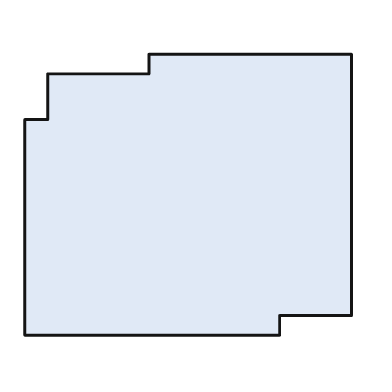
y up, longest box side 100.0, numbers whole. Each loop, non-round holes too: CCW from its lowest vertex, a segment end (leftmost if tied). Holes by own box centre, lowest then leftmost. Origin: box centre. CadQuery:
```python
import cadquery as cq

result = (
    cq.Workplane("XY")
    .moveTo(-50.0, -43.0)
    .lineTo(28.0, -43.0)
    .lineTo(28.0, -37.0)
    .lineTo(50.0, -37.0)
    .lineTo(50.0, 43.0)
    .lineTo(-12.0, 43.0)
    .lineTo(-12.0, 37.0)
    .lineTo(-43.0, 37.0)
    .lineTo(-43.0, 23.0)
    .lineTo(-50.0, 23.0)
    .close()
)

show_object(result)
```